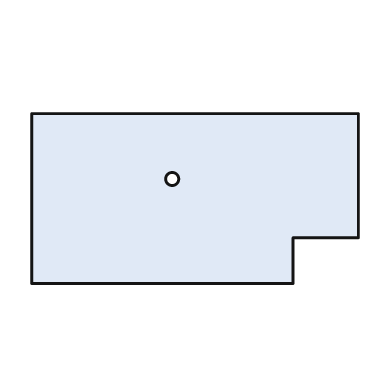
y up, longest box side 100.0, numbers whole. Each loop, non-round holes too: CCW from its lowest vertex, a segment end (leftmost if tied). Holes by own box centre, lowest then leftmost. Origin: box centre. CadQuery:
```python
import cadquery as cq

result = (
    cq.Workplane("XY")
    .moveTo(-50.0, -26.0)
    .lineTo(30.0, -26.0)
    .lineTo(30.0, -12.0)
    .lineTo(50.0, -12.0)
    .lineTo(50.0, 26.0)
    .lineTo(-50.0, 26.0)
    .close()
    .moveTo(-7.0, 6.0)
    .circle(2.0)
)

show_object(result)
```